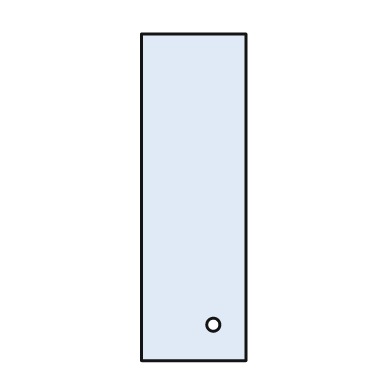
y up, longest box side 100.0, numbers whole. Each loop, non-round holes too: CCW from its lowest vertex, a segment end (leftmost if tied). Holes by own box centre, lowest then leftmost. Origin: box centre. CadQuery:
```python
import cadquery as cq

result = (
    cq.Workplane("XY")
    .moveTo(-16.0, -50.0)
    .lineTo(16.0, -50.0)
    .lineTo(16.0, 50.0)
    .lineTo(-16.0, 50.0)
    .close()
    .moveTo(6.0, -39.0)
    .circle(2.0)
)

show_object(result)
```